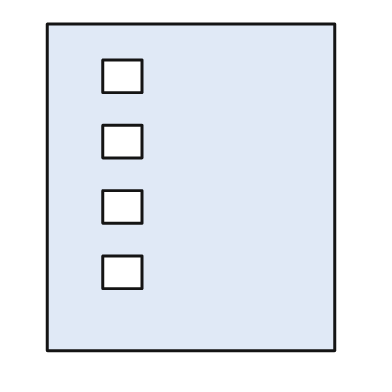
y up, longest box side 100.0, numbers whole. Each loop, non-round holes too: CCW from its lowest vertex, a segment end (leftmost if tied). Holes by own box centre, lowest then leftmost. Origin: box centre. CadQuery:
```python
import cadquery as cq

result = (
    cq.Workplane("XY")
    .moveTo(-44.0, -50.0)
    .lineTo(44.0, -50.0)
    .lineTo(44.0, 50.0)
    .lineTo(-44.0, 50.0)
    .close()
    .moveTo(-27.0, -31.0)
    .lineTo(-15.0, -31.0)
    .lineTo(-15.0, -21.0)
    .lineTo(-27.0, -21.0)
    .close()
    .moveTo(-27.0, -11.0)
    .lineTo(-15.0, -11.0)
    .lineTo(-15.0, -1.0)
    .lineTo(-27.0, -1.0)
    .close()
    .moveTo(-27.0, 9.0)
    .lineTo(-15.0, 9.0)
    .lineTo(-15.0, 19.0)
    .lineTo(-27.0, 19.0)
    .close()
    .moveTo(-27.0, 29.0)
    .lineTo(-15.0, 29.0)
    .lineTo(-15.0, 39.0)
    .lineTo(-27.0, 39.0)
    .close()
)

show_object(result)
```